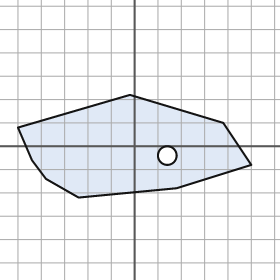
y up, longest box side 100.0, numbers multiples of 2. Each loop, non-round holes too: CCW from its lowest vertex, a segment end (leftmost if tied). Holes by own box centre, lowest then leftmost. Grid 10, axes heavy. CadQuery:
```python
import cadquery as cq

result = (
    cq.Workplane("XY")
    .moveTo(-24.0, -22.0)
    .lineTo(18.0, -18.0)
    .lineTo(50.0, -8.0)
    .lineTo(38.0, 10.0)
    .lineTo(-2.0, 22.0)
    .lineTo(-50.0, 8.0)
    .lineTo(-44.0, -6.0)
    .lineTo(-38.0, -14.0)
    .close()
    .moveTo(14.0, -4.0)
    .circle(4.0)
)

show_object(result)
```